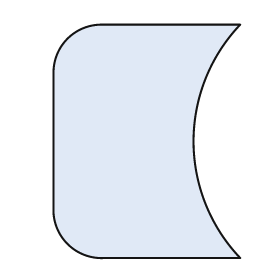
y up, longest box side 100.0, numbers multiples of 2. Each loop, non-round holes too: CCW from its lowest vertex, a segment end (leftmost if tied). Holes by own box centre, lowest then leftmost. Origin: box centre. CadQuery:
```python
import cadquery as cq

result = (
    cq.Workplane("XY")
    .moveTo(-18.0, -50.0)
    .lineTo(40.0, -50.0)
    .threePointArc((20.0, 0.0), (40.0, 50.0))
    .lineTo(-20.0, 50.0)
    .threePointArc((-34.0, 44.0), (-40.0, 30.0))
    .lineTo(-40.0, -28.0)
    .threePointArc((-34.0, -44.0), (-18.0, -50.0))
    .close()
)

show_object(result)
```